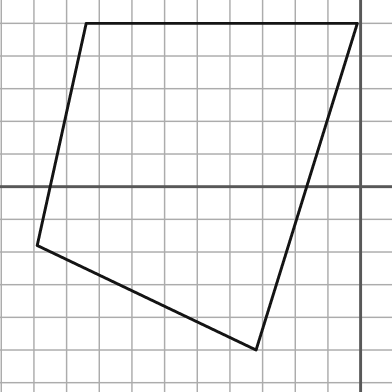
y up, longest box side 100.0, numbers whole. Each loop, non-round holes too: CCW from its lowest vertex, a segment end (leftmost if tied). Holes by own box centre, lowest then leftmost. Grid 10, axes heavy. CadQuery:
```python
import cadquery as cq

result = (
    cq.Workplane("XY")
    .moveTo(-32.0, -50.0)
    .lineTo(-1.0, 50.0)
    .lineTo(-84.0, 50.0)
    .lineTo(-99.0, -18.0)
    .close()
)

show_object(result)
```